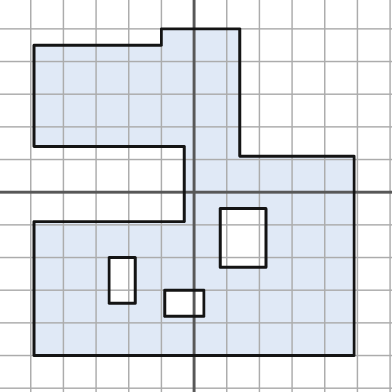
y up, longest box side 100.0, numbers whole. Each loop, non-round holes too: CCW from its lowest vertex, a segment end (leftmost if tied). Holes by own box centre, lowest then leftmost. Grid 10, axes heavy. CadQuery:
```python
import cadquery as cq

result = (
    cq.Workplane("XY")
    .moveTo(-49.0, -50.0)
    .lineTo(49.0, -50.0)
    .lineTo(49.0, 11.0)
    .lineTo(14.0, 11.0)
    .lineTo(14.0, 50.0)
    .lineTo(-10.0, 50.0)
    .lineTo(-10.0, 45.0)
    .lineTo(-49.0, 45.0)
    .lineTo(-49.0, 14.0)
    .lineTo(-3.0, 14.0)
    .lineTo(-3.0, -9.0)
    .lineTo(-49.0, -9.0)
    .close()
    .moveTo(-9.0, -38.0)
    .lineTo(3.0, -38.0)
    .lineTo(3.0, -30.0)
    .lineTo(-9.0, -30.0)
    .close()
    .moveTo(-26.0, -34.0)
    .lineTo(-18.0, -34.0)
    .lineTo(-18.0, -20.0)
    .lineTo(-26.0, -20.0)
    .close()
    .moveTo(8.0, -23.0)
    .lineTo(22.0, -23.0)
    .lineTo(22.0, -5.0)
    .lineTo(8.0, -5.0)
    .close()
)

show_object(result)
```